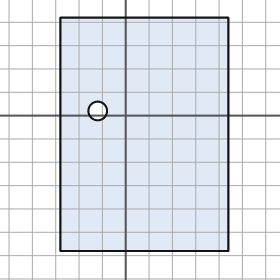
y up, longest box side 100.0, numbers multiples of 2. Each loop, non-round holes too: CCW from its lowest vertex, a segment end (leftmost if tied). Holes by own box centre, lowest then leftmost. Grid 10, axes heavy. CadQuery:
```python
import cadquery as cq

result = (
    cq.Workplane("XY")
    .moveTo(-28.0, -58.0)
    .lineTo(44.0, -58.0)
    .lineTo(44.0, 42.0)
    .lineTo(-28.0, 42.0)
    .close()
    .moveTo(-12.0, 2.0)
    .circle(4.0)
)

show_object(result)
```